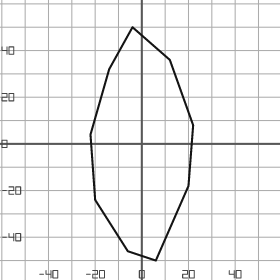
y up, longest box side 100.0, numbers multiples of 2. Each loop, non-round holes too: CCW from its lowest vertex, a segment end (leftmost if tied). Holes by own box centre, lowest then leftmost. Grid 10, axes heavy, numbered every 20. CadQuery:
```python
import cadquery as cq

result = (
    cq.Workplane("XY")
    .moveTo(6.0, -50.0)
    .lineTo(20.0, -18.0)
    .lineTo(22.0, 8.0)
    .lineTo(12.0, 36.0)
    .lineTo(-4.0, 50.0)
    .lineTo(-14.0, 32.0)
    .lineTo(-22.0, 4.0)
    .lineTo(-20.0, -24.0)
    .lineTo(-6.0, -46.0)
    .close()
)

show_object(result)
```